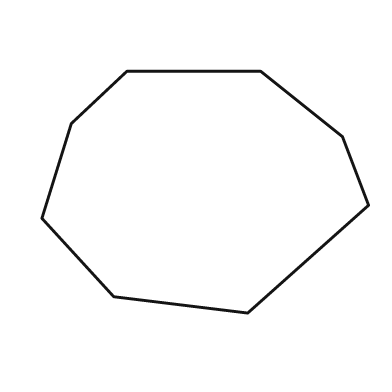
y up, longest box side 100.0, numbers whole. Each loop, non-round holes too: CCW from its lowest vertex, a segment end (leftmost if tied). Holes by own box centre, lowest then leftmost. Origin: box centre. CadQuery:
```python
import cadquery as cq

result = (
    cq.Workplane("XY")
    .moveTo(13.0, -37.0)
    .lineTo(50.0, -4.0)
    .lineTo(42.0, 17.0)
    .lineTo(17.0, 37.0)
    .lineTo(-24.0, 37.0)
    .lineTo(-41.0, 21.0)
    .lineTo(-50.0, -8.0)
    .lineTo(-28.0, -32.0)
    .close()
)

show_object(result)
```